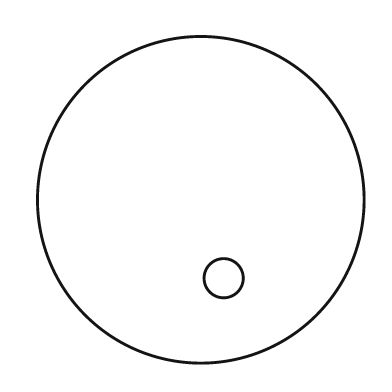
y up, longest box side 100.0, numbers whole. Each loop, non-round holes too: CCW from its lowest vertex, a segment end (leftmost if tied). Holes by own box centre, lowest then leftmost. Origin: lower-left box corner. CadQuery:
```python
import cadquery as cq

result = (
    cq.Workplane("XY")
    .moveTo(50.0, 50.0)
    .circle(50.0)
    .moveTo(57.0, 26.0)
    .circle(6.0)
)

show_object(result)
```